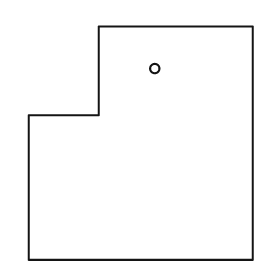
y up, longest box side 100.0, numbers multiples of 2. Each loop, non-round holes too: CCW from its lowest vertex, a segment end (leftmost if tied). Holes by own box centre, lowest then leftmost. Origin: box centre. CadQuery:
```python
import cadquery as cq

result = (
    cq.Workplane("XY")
    .moveTo(-48.0, -50.0)
    .lineTo(48.0, -50.0)
    .lineTo(48.0, 50.0)
    .lineTo(-18.0, 50.0)
    .lineTo(-18.0, 12.0)
    .lineTo(-48.0, 12.0)
    .close()
    .moveTo(6.0, 32.0)
    .circle(2.0)
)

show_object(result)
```